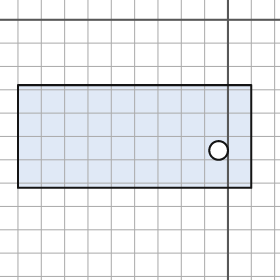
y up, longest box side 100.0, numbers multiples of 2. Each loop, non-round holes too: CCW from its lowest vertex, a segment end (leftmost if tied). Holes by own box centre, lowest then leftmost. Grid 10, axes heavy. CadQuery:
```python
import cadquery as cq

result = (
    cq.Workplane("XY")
    .moveTo(-90.0, -72.0)
    .lineTo(10.0, -72.0)
    .lineTo(10.0, -28.0)
    .lineTo(-90.0, -28.0)
    .close()
    .moveTo(-4.0, -56.0)
    .circle(4.0)
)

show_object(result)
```